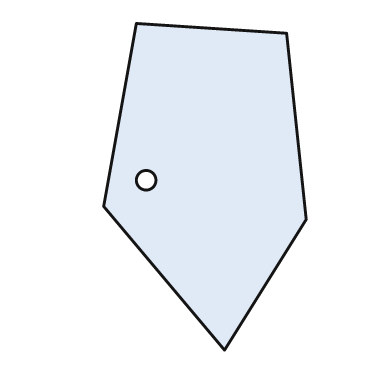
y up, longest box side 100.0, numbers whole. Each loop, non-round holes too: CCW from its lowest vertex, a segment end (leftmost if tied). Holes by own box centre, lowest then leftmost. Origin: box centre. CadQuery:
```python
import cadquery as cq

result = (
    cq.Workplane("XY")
    .moveTo(6.0, -50.0)
    .lineTo(31.0, -10.0)
    .lineTo(25.0, 47.0)
    .lineTo(-21.0, 50.0)
    .lineTo(-31.0, -6.0)
    .close()
    .moveTo(-18.0, 2.0)
    .circle(3.0)
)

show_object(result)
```